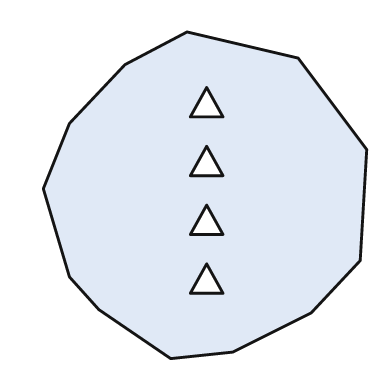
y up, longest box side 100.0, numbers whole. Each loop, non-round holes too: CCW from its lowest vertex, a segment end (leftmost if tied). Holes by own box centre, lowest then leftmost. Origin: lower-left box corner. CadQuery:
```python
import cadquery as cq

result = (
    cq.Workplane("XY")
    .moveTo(39.0, 0.0)
    .lineTo(58.0, 2.0)
    .lineTo(82.0, 14.0)
    .lineTo(97.0, 30.0)
    .lineTo(99.0, 64.0)
    .lineTo(78.0, 92.0)
    .lineTo(44.0, 100.0)
    .lineTo(25.0, 90.0)
    .lineTo(8.0, 72.0)
    .lineTo(0.0, 52.0)
    .lineTo(8.0, 25.0)
    .lineTo(17.0, 15.0)
    .close()
    .moveTo(45.0, 20.0)
    .lineTo(55.0, 20.0)
    .lineTo(50.0, 29.0)
    .close()
    .moveTo(45.0, 38.0)
    .lineTo(55.0, 38.0)
    .lineTo(50.0, 47.0)
    .close()
    .moveTo(45.0, 56.0)
    .lineTo(55.0, 56.0)
    .lineTo(50.0, 65.0)
    .close()
    .moveTo(45.0, 74.0)
    .lineTo(55.0, 74.0)
    .lineTo(50.0, 83.0)
    .close()
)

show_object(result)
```